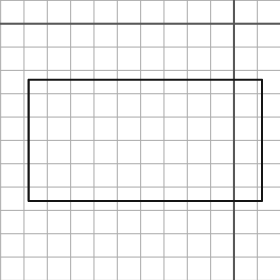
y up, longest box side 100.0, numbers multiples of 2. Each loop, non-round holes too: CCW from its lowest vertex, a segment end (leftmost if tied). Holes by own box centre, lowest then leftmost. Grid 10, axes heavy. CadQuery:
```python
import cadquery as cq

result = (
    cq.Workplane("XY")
    .moveTo(-88.0, -76.0)
    .lineTo(12.0, -76.0)
    .lineTo(12.0, -24.0)
    .lineTo(-88.0, -24.0)
    .close()
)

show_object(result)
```